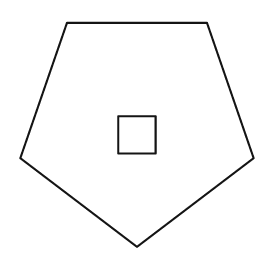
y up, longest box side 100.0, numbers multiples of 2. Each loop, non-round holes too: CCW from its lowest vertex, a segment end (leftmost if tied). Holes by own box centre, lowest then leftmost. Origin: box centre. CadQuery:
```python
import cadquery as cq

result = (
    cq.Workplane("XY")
    .moveTo(0.0, -48.0)
    .lineTo(50.0, -10.0)
    .lineTo(30.0, 48.0)
    .lineTo(-30.0, 48.0)
    .lineTo(-50.0, -10.0)
    .close()
    .moveTo(-8.0, -8.0)
    .lineTo(8.0, -8.0)
    .lineTo(8.0, 8.0)
    .lineTo(-8.0, 8.0)
    .close()
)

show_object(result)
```